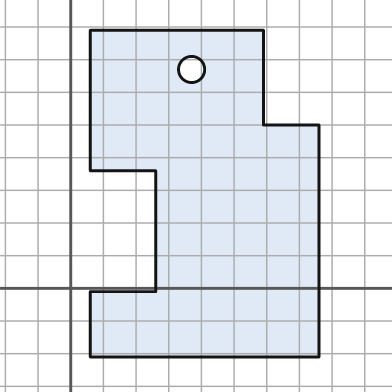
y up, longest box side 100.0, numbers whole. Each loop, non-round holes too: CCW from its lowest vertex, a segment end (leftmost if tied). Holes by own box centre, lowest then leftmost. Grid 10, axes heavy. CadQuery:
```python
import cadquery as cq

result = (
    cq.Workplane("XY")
    .moveTo(6.0, -21.0)
    .lineTo(76.0, -21.0)
    .lineTo(76.0, 50.0)
    .lineTo(59.0, 50.0)
    .lineTo(59.0, 79.0)
    .lineTo(6.0, 79.0)
    .lineTo(6.0, 36.0)
    .lineTo(26.0, 36.0)
    .lineTo(26.0, -1.0)
    .lineTo(6.0, -1.0)
    .close()
    .moveTo(37.0, 67.0)
    .circle(4.0)
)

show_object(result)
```